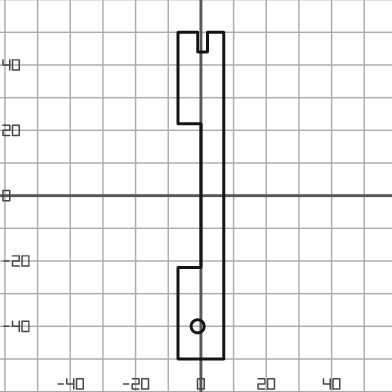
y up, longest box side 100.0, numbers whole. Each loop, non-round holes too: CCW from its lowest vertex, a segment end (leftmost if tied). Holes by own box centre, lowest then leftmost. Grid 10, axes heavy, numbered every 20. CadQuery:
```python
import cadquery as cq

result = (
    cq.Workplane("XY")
    .moveTo(-7.0, -50.0)
    .lineTo(7.0, -50.0)
    .lineTo(7.0, 50.0)
    .lineTo(2.0, 50.0)
    .lineTo(2.0, 44.0)
    .lineTo(-1.0, 44.0)
    .lineTo(-1.0, 50.0)
    .lineTo(-7.0, 50.0)
    .lineTo(-7.0, 22.0)
    .lineTo(0.0, 22.0)
    .lineTo(0.0, -22.0)
    .lineTo(-7.0, -22.0)
    .close()
    .moveTo(-1.0, -40.0)
    .circle(2.0)
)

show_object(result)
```